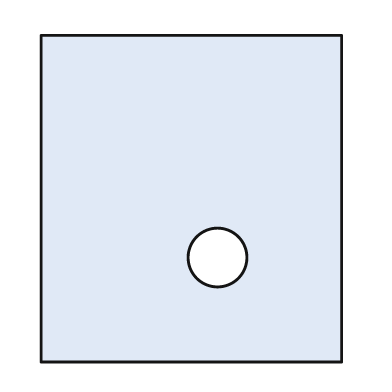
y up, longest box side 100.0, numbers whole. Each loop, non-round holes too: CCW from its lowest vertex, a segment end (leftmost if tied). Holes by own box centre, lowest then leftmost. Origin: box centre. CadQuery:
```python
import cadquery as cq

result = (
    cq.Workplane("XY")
    .moveTo(-46.0, -50.0)
    .lineTo(46.0, -50.0)
    .lineTo(46.0, 50.0)
    .lineTo(-46.0, 50.0)
    .close()
    .moveTo(8.0, -18.0)
    .circle(9.0)
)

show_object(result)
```